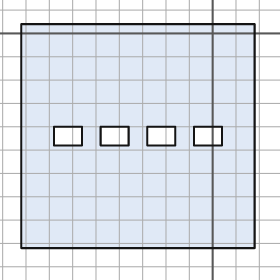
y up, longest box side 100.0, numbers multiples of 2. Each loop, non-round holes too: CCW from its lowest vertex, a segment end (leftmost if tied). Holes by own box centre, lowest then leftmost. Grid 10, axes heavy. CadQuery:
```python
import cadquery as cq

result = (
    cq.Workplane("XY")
    .moveTo(-82.0, -92.0)
    .lineTo(18.0, -92.0)
    .lineTo(18.0, 4.0)
    .lineTo(-82.0, 4.0)
    .close()
    .moveTo(-68.0, -48.0)
    .lineTo(-56.0, -48.0)
    .lineTo(-56.0, -40.0)
    .lineTo(-68.0, -40.0)
    .close()
    .moveTo(-48.0, -48.0)
    .lineTo(-36.0, -48.0)
    .lineTo(-36.0, -40.0)
    .lineTo(-48.0, -40.0)
    .close()
    .moveTo(-28.0, -48.0)
    .lineTo(-16.0, -48.0)
    .lineTo(-16.0, -40.0)
    .lineTo(-28.0, -40.0)
    .close()
    .moveTo(-8.0, -48.0)
    .lineTo(4.0, -48.0)
    .lineTo(4.0, -40.0)
    .lineTo(-8.0, -40.0)
    .close()
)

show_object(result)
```